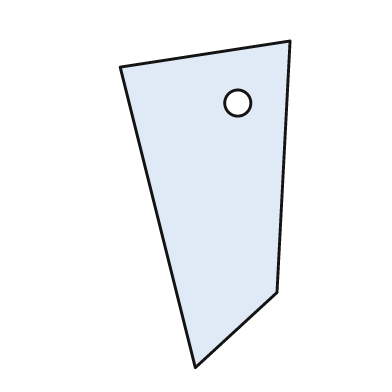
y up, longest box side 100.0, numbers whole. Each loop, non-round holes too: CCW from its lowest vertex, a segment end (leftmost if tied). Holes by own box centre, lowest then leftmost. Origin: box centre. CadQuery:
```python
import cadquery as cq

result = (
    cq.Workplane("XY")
    .moveTo(-3.0, -50.0)
    .lineTo(22.0, -27.0)
    .lineTo(26.0, 50.0)
    .lineTo(-26.0, 42.0)
    .close()
    .moveTo(10.0, 31.0)
    .circle(4.0)
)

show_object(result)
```